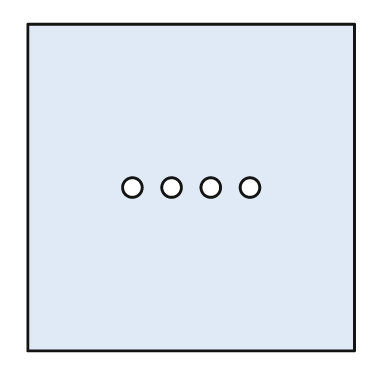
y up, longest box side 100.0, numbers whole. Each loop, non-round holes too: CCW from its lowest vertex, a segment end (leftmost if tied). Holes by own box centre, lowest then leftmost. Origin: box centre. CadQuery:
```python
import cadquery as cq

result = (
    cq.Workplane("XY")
    .moveTo(-50.0, -50.0)
    .lineTo(50.0, -50.0)
    .lineTo(50.0, 50.0)
    .lineTo(-50.0, 50.0)
    .close()
    .moveTo(-18.0, 0.0)
    .circle(3.0)
    .moveTo(-6.0, 0.0)
    .circle(3.0)
    .moveTo(6.0, 0.0)
    .circle(3.0)
    .moveTo(18.0, 0.0)
    .circle(3.0)
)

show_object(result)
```